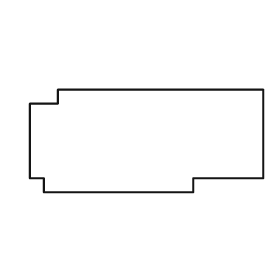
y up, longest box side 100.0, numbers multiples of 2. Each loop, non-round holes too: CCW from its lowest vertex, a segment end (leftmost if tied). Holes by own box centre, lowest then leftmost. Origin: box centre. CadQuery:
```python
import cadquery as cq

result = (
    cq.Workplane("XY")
    .moveTo(-44.0, -22.0)
    .lineTo(20.0, -22.0)
    .lineTo(20.0, -16.0)
    .lineTo(50.0, -16.0)
    .lineTo(50.0, 22.0)
    .lineTo(-38.0, 22.0)
    .lineTo(-38.0, 16.0)
    .lineTo(-50.0, 16.0)
    .lineTo(-50.0, -16.0)
    .lineTo(-44.0, -16.0)
    .close()
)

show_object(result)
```